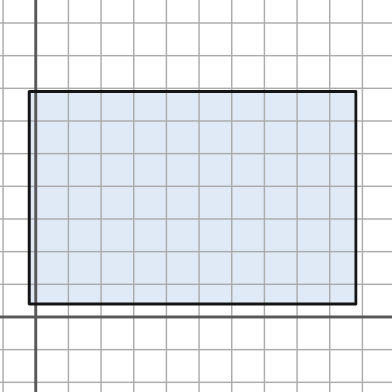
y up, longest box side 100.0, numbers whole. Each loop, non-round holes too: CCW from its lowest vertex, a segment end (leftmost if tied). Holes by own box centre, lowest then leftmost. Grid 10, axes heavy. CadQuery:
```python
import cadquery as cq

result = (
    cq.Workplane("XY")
    .moveTo(-2.0, 4.0)
    .lineTo(98.0, 4.0)
    .lineTo(98.0, 69.0)
    .lineTo(-2.0, 69.0)
    .close()
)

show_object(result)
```